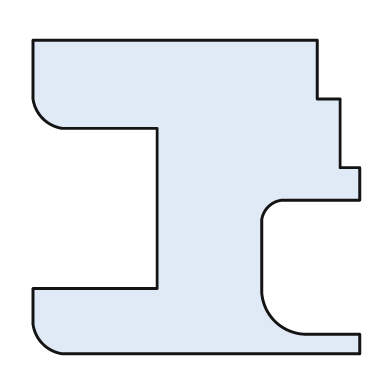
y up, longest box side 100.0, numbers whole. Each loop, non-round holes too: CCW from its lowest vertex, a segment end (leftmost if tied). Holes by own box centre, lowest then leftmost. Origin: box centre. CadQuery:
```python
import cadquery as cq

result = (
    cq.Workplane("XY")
    .moveTo(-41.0, -48.0)
    .lineTo(50.0, -48.0)
    .lineTo(50.0, -42.0)
    .lineTo(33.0, -42.0)
    .threePointArc((24.0, -38.0), (20.0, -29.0))
    .lineTo(20.0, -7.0)
    .threePointArc((22.0, -3.0), (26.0, -1.0))
    .lineTo(50.0, -1.0)
    .lineTo(50.0, 9.0)
    .lineTo(44.0, 9.0)
    .lineTo(44.0, 30.0)
    .lineTo(37.0, 30.0)
    .lineTo(37.0, 48.0)
    .lineTo(-50.0, 48.0)
    .lineTo(-50.0, 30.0)
    .threePointArc((-47.0, 24.0), (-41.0, 21.0))
    .lineTo(-12.0, 21.0)
    .lineTo(-12.0, -28.0)
    .lineTo(-50.0, -28.0)
    .lineTo(-50.0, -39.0)
    .threePointArc((-47.0, -45.0), (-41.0, -48.0))
    .close()
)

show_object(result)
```